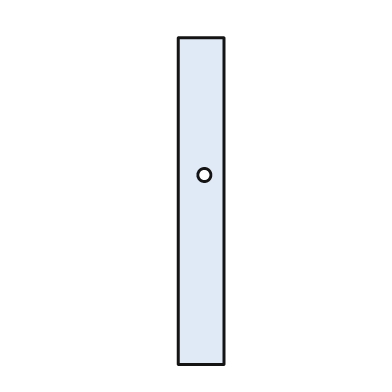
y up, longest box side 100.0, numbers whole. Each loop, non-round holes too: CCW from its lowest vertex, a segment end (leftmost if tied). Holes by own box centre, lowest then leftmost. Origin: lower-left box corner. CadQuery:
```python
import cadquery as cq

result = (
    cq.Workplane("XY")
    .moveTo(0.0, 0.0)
    .lineTo(14.0, 0.0)
    .lineTo(14.0, 100.0)
    .lineTo(0.0, 100.0)
    .close()
    .moveTo(8.0, 58.0)
    .circle(2.0)
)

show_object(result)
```